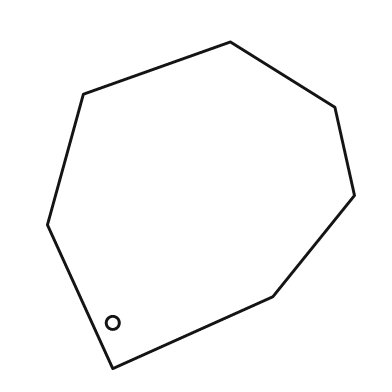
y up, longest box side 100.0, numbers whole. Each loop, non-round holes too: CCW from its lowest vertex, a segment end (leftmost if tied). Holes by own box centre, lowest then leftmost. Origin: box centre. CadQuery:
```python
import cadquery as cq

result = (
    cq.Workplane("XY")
    .moveTo(-27.0, -50.0)
    .lineTo(22.0, -28.0)
    .lineTo(47.0, 3.0)
    .lineTo(41.0, 30.0)
    .lineTo(9.0, 50.0)
    .lineTo(-36.0, 34.0)
    .lineTo(-47.0, -6.0)
    .close()
    .moveTo(-27.0, -36.0)
    .circle(2.0)
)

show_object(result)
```